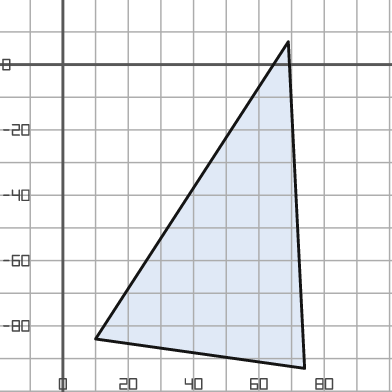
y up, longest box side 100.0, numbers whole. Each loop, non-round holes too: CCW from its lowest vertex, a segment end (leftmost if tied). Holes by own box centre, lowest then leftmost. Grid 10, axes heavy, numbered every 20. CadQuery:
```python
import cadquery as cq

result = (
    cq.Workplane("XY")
    .moveTo(74.0, -93.0)
    .lineTo(69.0, 7.0)
    .lineTo(10.0, -84.0)
    .close()
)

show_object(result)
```